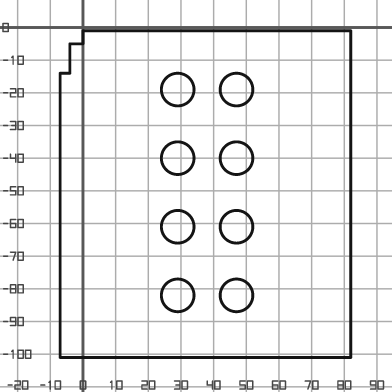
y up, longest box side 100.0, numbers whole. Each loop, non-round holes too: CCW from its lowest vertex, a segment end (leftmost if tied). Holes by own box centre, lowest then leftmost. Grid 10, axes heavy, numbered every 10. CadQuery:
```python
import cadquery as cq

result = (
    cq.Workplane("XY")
    .moveTo(-7.0, -101.0)
    .lineTo(82.0, -101.0)
    .lineTo(82.0, -1.0)
    .lineTo(0.0, -1.0)
    .lineTo(0.0, -5.0)
    .lineTo(-4.0, -5.0)
    .lineTo(-4.0, -14.0)
    .lineTo(-7.0, -14.0)
    .close()
    .moveTo(29.0, -82.0)
    .circle(5.0)
    .moveTo(47.0, -82.0)
    .circle(5.0)
    .moveTo(29.0, -61.0)
    .circle(5.0)
    .moveTo(47.0, -61.0)
    .circle(5.0)
    .moveTo(29.0, -40.0)
    .circle(5.0)
    .moveTo(47.0, -40.0)
    .circle(5.0)
    .moveTo(29.0, -19.0)
    .circle(5.0)
    .moveTo(47.0, -19.0)
    .circle(5.0)
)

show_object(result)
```